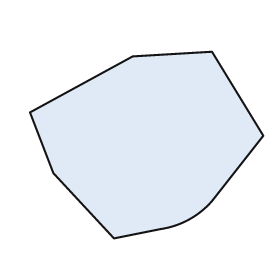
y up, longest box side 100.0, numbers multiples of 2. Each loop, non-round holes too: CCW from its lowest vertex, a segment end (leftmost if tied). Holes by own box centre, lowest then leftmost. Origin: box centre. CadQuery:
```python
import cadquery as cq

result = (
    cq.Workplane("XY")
    .moveTo(-14.0, -40.0)
    .lineTo(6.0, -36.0)
    .threePointArc((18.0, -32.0), (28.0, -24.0))
    .lineTo(50.0, 4.0)
    .lineTo(28.0, 40.0)
    .lineTo(-6.0, 38.0)
    .lineTo(-50.0, 14.0)
    .lineTo(-40.0, -12.0)
    .close()
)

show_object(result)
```